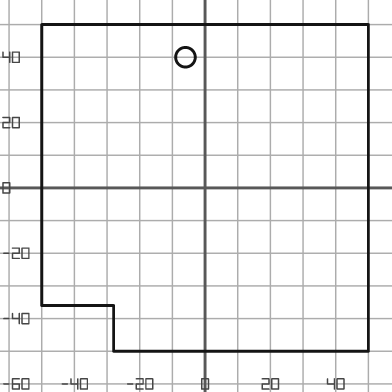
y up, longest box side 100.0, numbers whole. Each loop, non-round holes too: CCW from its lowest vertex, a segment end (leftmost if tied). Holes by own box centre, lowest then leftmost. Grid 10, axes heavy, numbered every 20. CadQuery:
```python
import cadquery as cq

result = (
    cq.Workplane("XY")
    .moveTo(-28.0, -50.0)
    .lineTo(50.0, -50.0)
    .lineTo(50.0, 50.0)
    .lineTo(-50.0, 50.0)
    .lineTo(-50.0, -36.0)
    .lineTo(-28.0, -36.0)
    .close()
    .moveTo(-6.0, 40.0)
    .circle(3.0)
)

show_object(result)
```